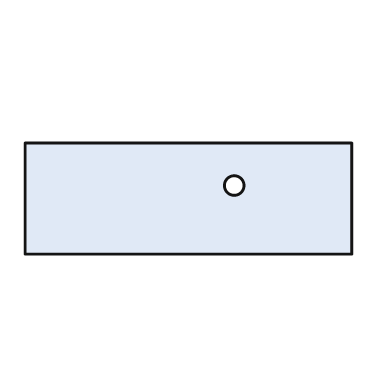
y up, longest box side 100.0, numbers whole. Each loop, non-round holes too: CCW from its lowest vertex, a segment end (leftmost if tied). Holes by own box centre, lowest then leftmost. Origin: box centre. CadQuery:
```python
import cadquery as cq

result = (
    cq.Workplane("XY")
    .moveTo(-50.0, -17.0)
    .lineTo(50.0, -17.0)
    .lineTo(50.0, 17.0)
    .lineTo(-50.0, 17.0)
    .close()
    .moveTo(14.0, 4.0)
    .circle(3.0)
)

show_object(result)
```